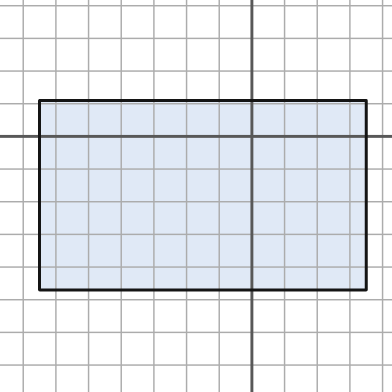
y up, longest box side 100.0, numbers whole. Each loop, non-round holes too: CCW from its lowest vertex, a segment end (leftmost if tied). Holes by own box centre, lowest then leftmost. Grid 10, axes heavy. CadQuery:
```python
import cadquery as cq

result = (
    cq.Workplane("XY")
    .moveTo(-65.0, -47.0)
    .lineTo(35.0, -47.0)
    .lineTo(35.0, 11.0)
    .lineTo(-65.0, 11.0)
    .close()
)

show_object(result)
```